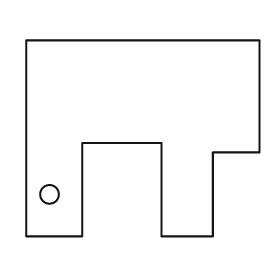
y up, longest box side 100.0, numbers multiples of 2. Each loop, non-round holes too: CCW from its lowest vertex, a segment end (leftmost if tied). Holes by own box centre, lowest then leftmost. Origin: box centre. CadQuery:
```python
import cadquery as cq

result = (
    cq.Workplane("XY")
    .moveTo(-50.0, -42.0)
    .lineTo(-26.0, -42.0)
    .lineTo(-26.0, -2.0)
    .lineTo(8.0, -2.0)
    .lineTo(8.0, -42.0)
    .lineTo(30.0, -42.0)
    .lineTo(30.0, -6.0)
    .lineTo(50.0, -6.0)
    .lineTo(50.0, 42.0)
    .lineTo(-50.0, 42.0)
    .close()
    .moveTo(-40.0, -24.0)
    .circle(4.0)
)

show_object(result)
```